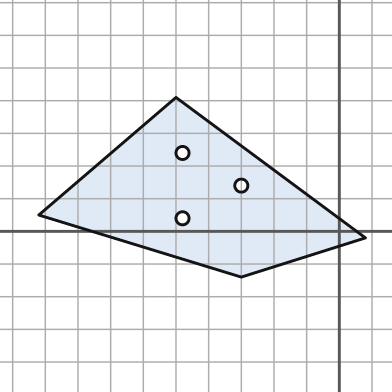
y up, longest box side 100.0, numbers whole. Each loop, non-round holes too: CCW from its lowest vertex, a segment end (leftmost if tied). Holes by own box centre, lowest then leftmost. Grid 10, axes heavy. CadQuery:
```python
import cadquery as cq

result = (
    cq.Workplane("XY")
    .moveTo(-30.0, -14.0)
    .lineTo(8.0, -2.0)
    .lineTo(-50.0, 41.0)
    .lineTo(-92.0, 5.0)
    .close()
    .moveTo(-48.0, 4.0)
    .circle(2.0)
    .moveTo(-30.0, 14.0)
    .circle(2.0)
    .moveTo(-48.0, 24.0)
    .circle(2.0)
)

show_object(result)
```